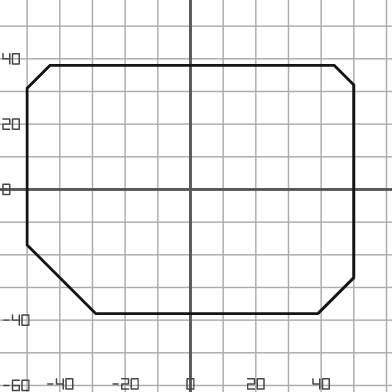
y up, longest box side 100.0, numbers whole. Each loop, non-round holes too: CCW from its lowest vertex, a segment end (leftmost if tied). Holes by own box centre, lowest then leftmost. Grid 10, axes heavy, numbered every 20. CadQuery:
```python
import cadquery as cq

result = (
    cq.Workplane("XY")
    .moveTo(-29.0, -38.0)
    .lineTo(39.0, -38.0)
    .lineTo(50.0, -27.0)
    .lineTo(50.0, 32.0)
    .lineTo(44.0, 38.0)
    .lineTo(-43.0, 38.0)
    .lineTo(-50.0, 31.0)
    .lineTo(-50.0, -17.0)
    .close()
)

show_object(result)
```